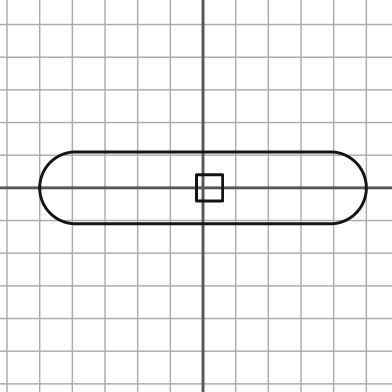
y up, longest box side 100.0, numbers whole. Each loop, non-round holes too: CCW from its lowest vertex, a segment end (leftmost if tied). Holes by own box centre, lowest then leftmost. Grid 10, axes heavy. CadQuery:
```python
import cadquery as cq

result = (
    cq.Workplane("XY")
    .moveTo(-39.0, -11.0)
    .lineTo(39.0, -11.0)
    .threePointArc((50.0, 0.0), (39.0, 11.0))
    .lineTo(-39.0, 11.0)
    .threePointArc((-50.0, 0.0), (-39.0, -11.0))
    .close()
    .moveTo(-2.0, -4.0)
    .lineTo(6.0, -4.0)
    .lineTo(6.0, 4.0)
    .lineTo(-2.0, 4.0)
    .close()
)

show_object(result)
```